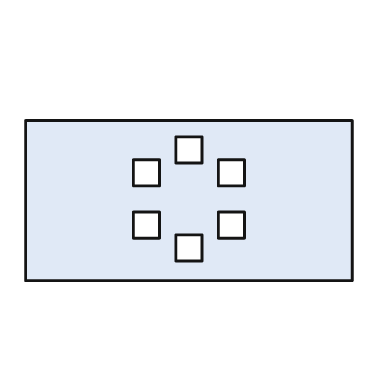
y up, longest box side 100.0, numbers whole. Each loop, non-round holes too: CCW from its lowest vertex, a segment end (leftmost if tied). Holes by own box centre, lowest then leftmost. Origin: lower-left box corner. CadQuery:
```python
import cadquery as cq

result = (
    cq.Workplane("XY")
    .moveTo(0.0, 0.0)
    .lineTo(100.0, 0.0)
    .lineTo(100.0, 49.0)
    .lineTo(0.0, 49.0)
    .close()
    .moveTo(46.0, 6.0)
    .lineTo(54.0, 6.0)
    .lineTo(54.0, 14.0)
    .lineTo(46.0, 14.0)
    .close()
    .moveTo(33.0, 13.0)
    .lineTo(41.0, 13.0)
    .lineTo(41.0, 21.0)
    .lineTo(33.0, 21.0)
    .close()
    .moveTo(59.0, 13.0)
    .lineTo(67.0, 13.0)
    .lineTo(67.0, 21.0)
    .lineTo(59.0, 21.0)
    .close()
    .moveTo(33.0, 29.0)
    .lineTo(41.0, 29.0)
    .lineTo(41.0, 37.0)
    .lineTo(33.0, 37.0)
    .close()
    .moveTo(59.0, 29.0)
    .lineTo(67.0, 29.0)
    .lineTo(67.0, 37.0)
    .lineTo(59.0, 37.0)
    .close()
    .moveTo(46.0, 36.0)
    .lineTo(54.0, 36.0)
    .lineTo(54.0, 44.0)
    .lineTo(46.0, 44.0)
    .close()
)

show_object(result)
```